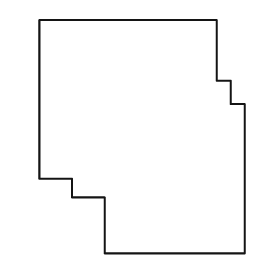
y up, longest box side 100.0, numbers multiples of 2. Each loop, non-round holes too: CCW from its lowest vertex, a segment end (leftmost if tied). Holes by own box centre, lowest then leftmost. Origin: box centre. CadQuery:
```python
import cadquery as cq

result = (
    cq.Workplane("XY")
    .moveTo(-16.0, -50.0)
    .lineTo(44.0, -50.0)
    .lineTo(44.0, 14.0)
    .lineTo(38.0, 14.0)
    .lineTo(38.0, 24.0)
    .lineTo(32.0, 24.0)
    .lineTo(32.0, 50.0)
    .lineTo(-44.0, 50.0)
    .lineTo(-44.0, -18.0)
    .lineTo(-30.0, -18.0)
    .lineTo(-30.0, -26.0)
    .lineTo(-16.0, -26.0)
    .close()
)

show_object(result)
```